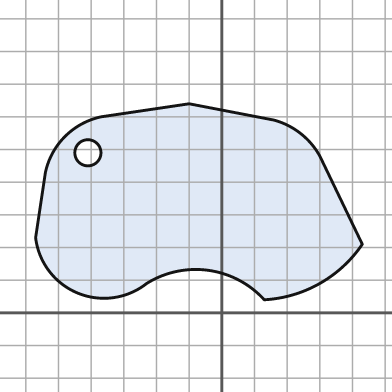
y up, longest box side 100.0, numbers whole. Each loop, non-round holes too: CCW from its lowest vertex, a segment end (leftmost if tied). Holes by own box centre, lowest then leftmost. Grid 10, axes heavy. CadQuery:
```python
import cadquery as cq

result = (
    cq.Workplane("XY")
    .moveTo(13.0, 4.0)
    .threePointArc((30.0, 9.0), (43.0, 21.0))
    .lineTo(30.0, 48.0)
    .threePointArc((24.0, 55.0), (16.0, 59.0))
    .lineTo(-10.0, 64.0)
    .lineTo(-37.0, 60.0)
    .threePointArc((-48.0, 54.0), (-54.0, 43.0))
    .lineTo(-57.0, 23.0)
    .threePointArc((-44.0, 6.0), (-23.0, 9.0))
    .threePointArc((-4.0, 13.0), (13.0, 4.0))
    .close()
    .moveTo(-41.0, 49.0)
    .circle(4.0)
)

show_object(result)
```